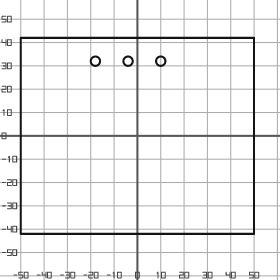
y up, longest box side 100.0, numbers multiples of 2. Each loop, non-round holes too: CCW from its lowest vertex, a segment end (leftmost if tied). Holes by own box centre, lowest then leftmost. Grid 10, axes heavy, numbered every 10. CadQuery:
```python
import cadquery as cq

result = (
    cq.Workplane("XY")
    .moveTo(-50.0, -42.0)
    .lineTo(50.0, -42.0)
    .lineTo(50.0, 42.0)
    .lineTo(-50.0, 42.0)
    .close()
    .moveTo(-18.0, 32.0)
    .circle(2.0)
    .moveTo(-4.0, 32.0)
    .circle(2.0)
    .moveTo(10.0, 32.0)
    .circle(2.0)
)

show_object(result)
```